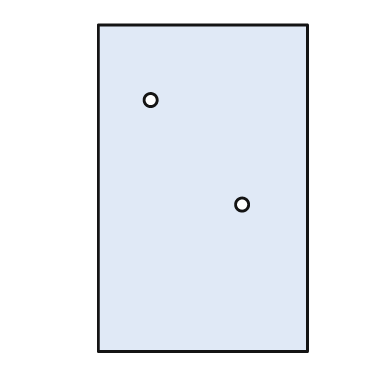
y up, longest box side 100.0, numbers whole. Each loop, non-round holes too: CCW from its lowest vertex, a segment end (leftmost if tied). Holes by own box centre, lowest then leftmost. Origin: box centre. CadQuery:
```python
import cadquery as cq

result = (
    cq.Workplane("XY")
    .moveTo(-32.0, -50.0)
    .lineTo(32.0, -50.0)
    .lineTo(32.0, 50.0)
    .lineTo(-32.0, 50.0)
    .close()
    .moveTo(12.0, -5.0)
    .circle(2.0)
    .moveTo(-16.0, 27.0)
    .circle(2.0)
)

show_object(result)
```